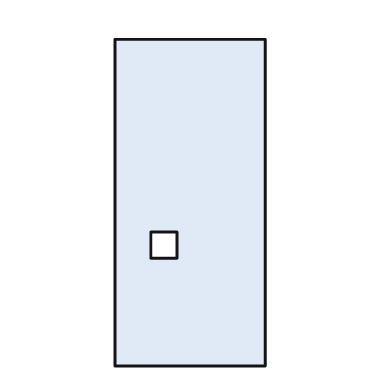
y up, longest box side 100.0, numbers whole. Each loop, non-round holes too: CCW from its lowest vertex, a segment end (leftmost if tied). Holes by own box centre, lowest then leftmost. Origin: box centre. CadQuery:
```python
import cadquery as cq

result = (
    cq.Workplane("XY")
    .moveTo(-23.0, -50.0)
    .lineTo(23.0, -50.0)
    .lineTo(23.0, 50.0)
    .lineTo(-23.0, 50.0)
    .close()
    .moveTo(-12.0, -17.0)
    .lineTo(-4.0, -17.0)
    .lineTo(-4.0, -9.0)
    .lineTo(-12.0, -9.0)
    .close()
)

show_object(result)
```